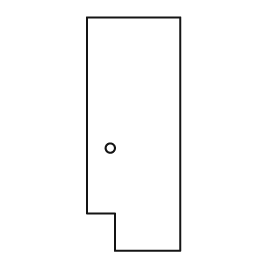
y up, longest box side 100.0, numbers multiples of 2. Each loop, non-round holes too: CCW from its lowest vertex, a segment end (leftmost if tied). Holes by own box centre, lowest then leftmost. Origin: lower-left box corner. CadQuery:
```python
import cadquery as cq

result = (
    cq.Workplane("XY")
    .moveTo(12.0, 0.0)
    .lineTo(40.0, 0.0)
    .lineTo(40.0, 100.0)
    .lineTo(0.0, 100.0)
    .lineTo(0.0, 16.0)
    .lineTo(12.0, 16.0)
    .close()
    .moveTo(10.0, 44.0)
    .circle(2.0)
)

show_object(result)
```